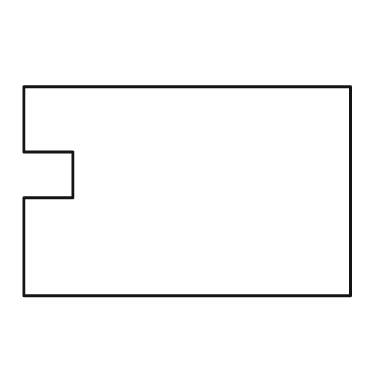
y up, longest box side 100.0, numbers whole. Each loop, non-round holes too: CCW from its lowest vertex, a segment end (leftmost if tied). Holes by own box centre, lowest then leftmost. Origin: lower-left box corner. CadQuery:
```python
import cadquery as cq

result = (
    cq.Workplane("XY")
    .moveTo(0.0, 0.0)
    .lineTo(100.0, 0.0)
    .lineTo(100.0, 64.0)
    .lineTo(0.0, 64.0)
    .lineTo(0.0, 44.0)
    .lineTo(15.0, 44.0)
    .lineTo(15.0, 30.0)
    .lineTo(0.0, 30.0)
    .close()
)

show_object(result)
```